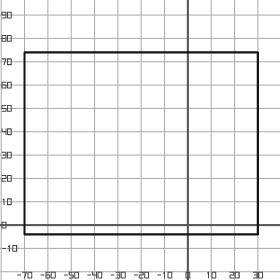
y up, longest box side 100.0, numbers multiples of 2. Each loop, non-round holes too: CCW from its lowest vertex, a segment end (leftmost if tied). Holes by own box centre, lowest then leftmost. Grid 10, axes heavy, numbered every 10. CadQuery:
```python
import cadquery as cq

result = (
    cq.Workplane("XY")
    .moveTo(-70.0, -4.0)
    .lineTo(30.0, -4.0)
    .lineTo(30.0, 74.0)
    .lineTo(-70.0, 74.0)
    .close()
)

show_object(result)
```